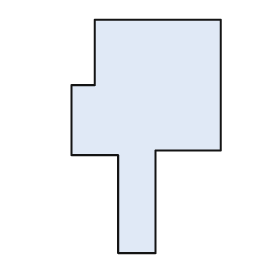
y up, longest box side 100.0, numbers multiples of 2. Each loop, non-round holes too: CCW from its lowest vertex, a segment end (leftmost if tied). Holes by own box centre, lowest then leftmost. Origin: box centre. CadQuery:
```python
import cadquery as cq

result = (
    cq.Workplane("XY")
    .moveTo(-12.0, -50.0)
    .lineTo(4.0, -50.0)
    .lineTo(4.0, -6.0)
    .lineTo(32.0, -6.0)
    .lineTo(32.0, 50.0)
    .lineTo(-22.0, 50.0)
    .lineTo(-22.0, 22.0)
    .lineTo(-32.0, 22.0)
    .lineTo(-32.0, -8.0)
    .lineTo(-12.0, -8.0)
    .close()
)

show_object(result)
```